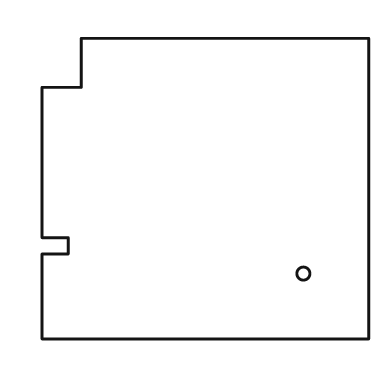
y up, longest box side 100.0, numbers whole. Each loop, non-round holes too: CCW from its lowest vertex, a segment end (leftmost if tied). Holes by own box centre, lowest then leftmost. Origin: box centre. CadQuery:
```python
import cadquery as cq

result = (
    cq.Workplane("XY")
    .moveTo(-50.0, -46.0)
    .lineTo(50.0, -46.0)
    .lineTo(50.0, 46.0)
    .lineTo(-38.0, 46.0)
    .lineTo(-38.0, 31.0)
    .lineTo(-50.0, 31.0)
    .lineTo(-50.0, -15.0)
    .lineTo(-42.0, -15.0)
    .lineTo(-42.0, -20.0)
    .lineTo(-50.0, -20.0)
    .close()
    .moveTo(30.0, -26.0)
    .circle(2.0)
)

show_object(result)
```